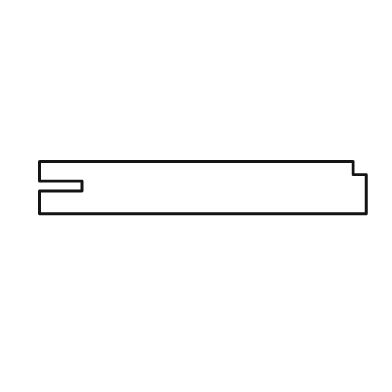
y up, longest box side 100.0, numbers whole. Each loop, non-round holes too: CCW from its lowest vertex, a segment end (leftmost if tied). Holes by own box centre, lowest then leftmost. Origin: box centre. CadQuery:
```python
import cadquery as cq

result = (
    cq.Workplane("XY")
    .moveTo(-50.0, -8.0)
    .lineTo(50.0, -8.0)
    .lineTo(50.0, 4.0)
    .lineTo(46.0, 4.0)
    .lineTo(46.0, 8.0)
    .lineTo(-50.0, 8.0)
    .lineTo(-50.0, 2.0)
    .lineTo(-37.0, 2.0)
    .lineTo(-37.0, -1.0)
    .lineTo(-50.0, -1.0)
    .close()
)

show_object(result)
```